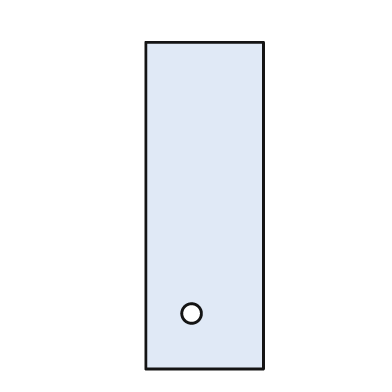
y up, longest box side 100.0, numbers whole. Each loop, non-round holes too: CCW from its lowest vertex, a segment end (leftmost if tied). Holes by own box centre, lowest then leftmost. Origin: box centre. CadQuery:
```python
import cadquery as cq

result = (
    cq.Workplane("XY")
    .moveTo(-18.0, -50.0)
    .lineTo(18.0, -50.0)
    .lineTo(18.0, 50.0)
    .lineTo(-18.0, 50.0)
    .close()
    .moveTo(-4.0, -33.0)
    .circle(3.0)
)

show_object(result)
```